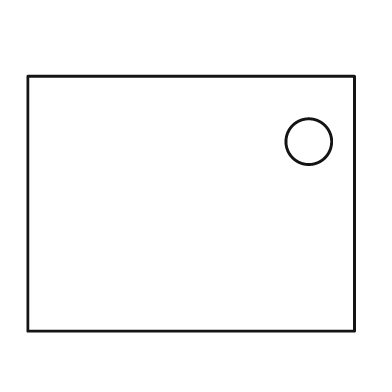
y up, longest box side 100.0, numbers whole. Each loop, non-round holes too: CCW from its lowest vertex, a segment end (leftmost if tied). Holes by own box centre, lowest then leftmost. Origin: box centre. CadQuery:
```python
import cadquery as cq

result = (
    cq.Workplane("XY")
    .moveTo(-50.0, -39.0)
    .lineTo(50.0, -39.0)
    .lineTo(50.0, 39.0)
    .lineTo(-50.0, 39.0)
    .close()
    .moveTo(36.0, 19.0)
    .circle(7.0)
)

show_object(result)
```